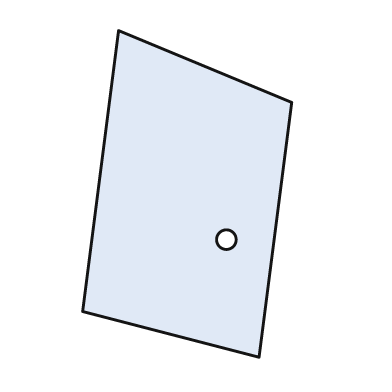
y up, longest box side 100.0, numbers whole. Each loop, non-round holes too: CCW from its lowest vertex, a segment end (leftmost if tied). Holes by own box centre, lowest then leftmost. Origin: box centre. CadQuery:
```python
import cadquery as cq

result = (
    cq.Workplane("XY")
    .moveTo(22.0, -50.0)
    .lineTo(32.0, 28.0)
    .lineTo(-21.0, 50.0)
    .lineTo(-32.0, -36.0)
    .close()
    .moveTo(12.0, -14.0)
    .circle(3.0)
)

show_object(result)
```